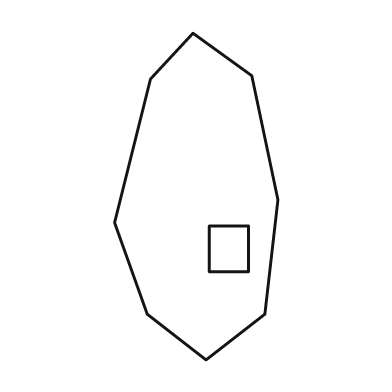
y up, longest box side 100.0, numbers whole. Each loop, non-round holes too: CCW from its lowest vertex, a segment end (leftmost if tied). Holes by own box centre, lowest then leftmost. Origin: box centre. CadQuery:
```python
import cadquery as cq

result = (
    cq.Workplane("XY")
    .moveTo(3.0, -50.0)
    .lineTo(21.0, -36.0)
    .lineTo(25.0, -1.0)
    .lineTo(17.0, 37.0)
    .lineTo(-1.0, 50.0)
    .lineTo(-14.0, 36.0)
    .lineTo(-25.0, -8.0)
    .lineTo(-15.0, -36.0)
    .close()
    .moveTo(4.0, -23.0)
    .lineTo(16.0, -23.0)
    .lineTo(16.0, -9.0)
    .lineTo(4.0, -9.0)
    .close()
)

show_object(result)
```